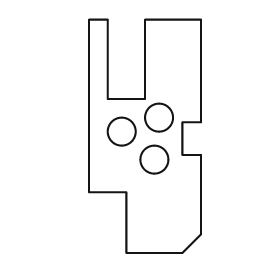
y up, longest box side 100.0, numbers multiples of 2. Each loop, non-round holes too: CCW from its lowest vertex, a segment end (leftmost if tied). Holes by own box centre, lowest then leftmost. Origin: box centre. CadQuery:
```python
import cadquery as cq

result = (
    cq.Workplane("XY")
    .moveTo(-8.0, -50.0)
    .lineTo(16.0, -50.0)
    .lineTo(24.0, -42.0)
    .lineTo(24.0, -8.0)
    .lineTo(16.0, -8.0)
    .lineTo(16.0, 6.0)
    .lineTo(24.0, 6.0)
    .lineTo(24.0, 50.0)
    .lineTo(0.0, 50.0)
    .lineTo(0.0, 16.0)
    .lineTo(-16.0, 16.0)
    .lineTo(-16.0, 50.0)
    .lineTo(-24.0, 50.0)
    .lineTo(-24.0, -24.0)
    .lineTo(-8.0, -24.0)
    .close()
    .moveTo(4.0, -10.0)
    .circle(6.0)
    .moveTo(-10.0, 2.0)
    .circle(6.0)
    .moveTo(6.0, 8.0)
    .circle(6.0)
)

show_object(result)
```